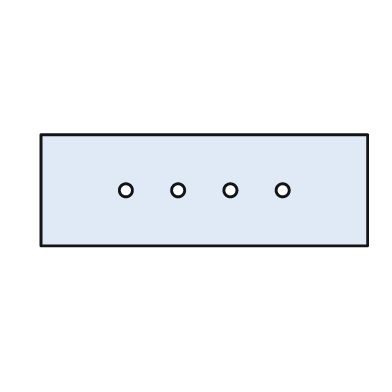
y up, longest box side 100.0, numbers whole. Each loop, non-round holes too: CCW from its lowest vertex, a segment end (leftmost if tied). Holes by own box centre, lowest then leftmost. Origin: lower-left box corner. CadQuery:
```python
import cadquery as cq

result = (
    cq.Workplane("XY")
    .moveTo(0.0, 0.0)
    .lineTo(100.0, 0.0)
    .lineTo(100.0, 34.0)
    .lineTo(0.0, 34.0)
    .close()
    .moveTo(26.0, 17.0)
    .circle(2.0)
    .moveTo(42.0, 17.0)
    .circle(2.0)
    .moveTo(58.0, 17.0)
    .circle(2.0)
    .moveTo(74.0, 17.0)
    .circle(2.0)
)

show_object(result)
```